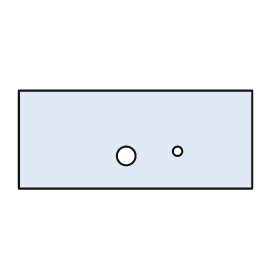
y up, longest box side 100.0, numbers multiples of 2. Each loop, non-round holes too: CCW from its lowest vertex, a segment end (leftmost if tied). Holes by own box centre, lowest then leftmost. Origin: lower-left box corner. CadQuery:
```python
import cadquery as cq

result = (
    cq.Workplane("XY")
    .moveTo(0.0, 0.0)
    .lineTo(100.0, 0.0)
    .lineTo(100.0, 42.0)
    .lineTo(0.0, 42.0)
    .close()
    .moveTo(46.0, 14.0)
    .circle(4.0)
    .moveTo(68.0, 16.0)
    .circle(2.0)
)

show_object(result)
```